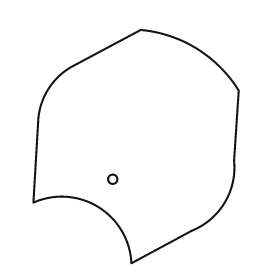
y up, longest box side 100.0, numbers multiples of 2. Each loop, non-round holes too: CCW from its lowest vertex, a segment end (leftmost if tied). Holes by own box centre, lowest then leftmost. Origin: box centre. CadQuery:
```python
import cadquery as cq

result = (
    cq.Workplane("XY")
    .moveTo(-2.0, -50.0)
    .lineTo(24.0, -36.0)
    .threePointArc((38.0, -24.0), (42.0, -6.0))
    .lineTo(44.0, 24.0)
    .threePointArc((26.0, 42.0), (2.0, 50.0))
    .lineTo(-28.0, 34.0)
    .threePointArc((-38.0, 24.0), (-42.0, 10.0))
    .lineTo(-44.0, -24.0)
    .threePointArc((-16.0, -26.0), (-2.0, -50.0))
    .close()
    .moveTo(-10.0, -14.0)
    .circle(2.0)
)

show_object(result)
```